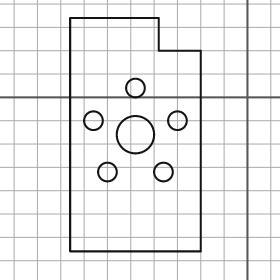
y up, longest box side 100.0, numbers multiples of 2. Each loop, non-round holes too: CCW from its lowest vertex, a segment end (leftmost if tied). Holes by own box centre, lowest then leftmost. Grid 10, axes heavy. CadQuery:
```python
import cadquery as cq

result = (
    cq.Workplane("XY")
    .moveTo(-76.0, -66.0)
    .lineTo(-20.0, -66.0)
    .lineTo(-20.0, 20.0)
    .lineTo(-38.0, 20.0)
    .lineTo(-38.0, 34.0)
    .lineTo(-76.0, 34.0)
    .close()
    .moveTo(-60.0, -32.0)
    .circle(4.0)
    .moveTo(-36.0, -32.0)
    .circle(4.0)
    .moveTo(-48.0, -16.0)
    .circle(8.0)
    .moveTo(-66.0, -10.0)
    .circle(4.0)
    .moveTo(-30.0, -10.0)
    .circle(4.0)
    .moveTo(-48.0, 4.0)
    .circle(4.0)
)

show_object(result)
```